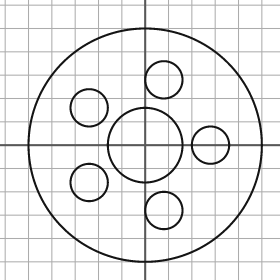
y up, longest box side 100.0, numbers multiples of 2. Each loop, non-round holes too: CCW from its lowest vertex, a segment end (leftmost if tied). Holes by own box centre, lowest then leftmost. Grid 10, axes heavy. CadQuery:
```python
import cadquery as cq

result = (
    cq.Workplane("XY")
    .moveTo(0.0, 0.0)
    .circle(50.0)
    .moveTo(8.0, -28.0)
    .circle(8.0)
    .moveTo(-24.0, -16.0)
    .circle(8.0)
    .moveTo(0.0, 0.0)
    .circle(16.0)
    .moveTo(28.0, 0.0)
    .circle(8.0)
    .moveTo(-24.0, 16.0)
    .circle(8.0)
    .moveTo(8.0, 28.0)
    .circle(8.0)
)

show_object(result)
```